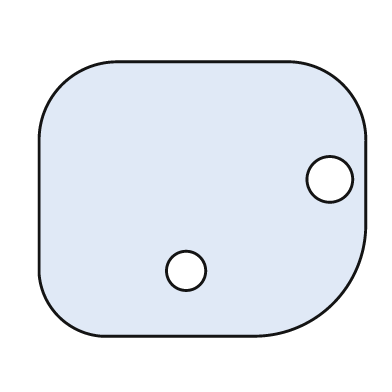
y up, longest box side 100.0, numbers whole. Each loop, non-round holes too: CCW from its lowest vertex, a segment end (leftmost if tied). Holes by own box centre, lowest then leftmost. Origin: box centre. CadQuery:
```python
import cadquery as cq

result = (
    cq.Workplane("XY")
    .moveTo(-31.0, -42.0)
    .lineTo(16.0, -42.0)
    .threePointArc((40.0, -32.0), (50.0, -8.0))
    .lineTo(50.0, 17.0)
    .threePointArc((43.0, 35.0), (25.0, 42.0))
    .lineTo(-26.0, 42.0)
    .threePointArc((-43.0, 35.0), (-50.0, 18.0))
    .lineTo(-50.0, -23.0)
    .threePointArc((-44.0, -36.0), (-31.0, -42.0))
    .close()
    .moveTo(-5.0, -22.0)
    .circle(6.0)
    .moveTo(39.0, 6.0)
    .circle(7.0)
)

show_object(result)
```